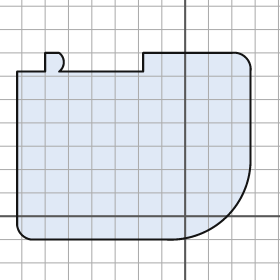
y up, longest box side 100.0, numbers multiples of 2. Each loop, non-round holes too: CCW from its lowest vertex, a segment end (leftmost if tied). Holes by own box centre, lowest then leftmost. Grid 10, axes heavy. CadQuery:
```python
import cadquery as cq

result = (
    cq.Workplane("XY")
    .moveTo(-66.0, -10.0)
    .lineTo(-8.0, -10.0)
    .threePointArc((18.0, 0.0), (28.0, 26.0))
    .lineTo(28.0, 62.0)
    .threePointArc((26.0, 68.0), (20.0, 70.0))
    .lineTo(-18.0, 70.0)
    .lineTo(-18.0, 62.0)
    .lineTo(-54.0, 62.0)
    .threePointArc((-52.0, 66.0), (-54.0, 70.0))
    .lineTo(-60.0, 70.0)
    .lineTo(-60.0, 62.0)
    .lineTo(-72.0, 62.0)
    .lineTo(-72.0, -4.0)
    .threePointArc((-70.0, -8.0), (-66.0, -10.0))
    .close()
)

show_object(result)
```